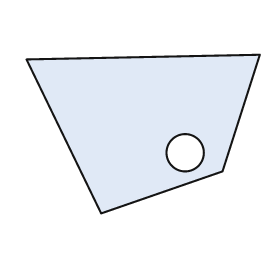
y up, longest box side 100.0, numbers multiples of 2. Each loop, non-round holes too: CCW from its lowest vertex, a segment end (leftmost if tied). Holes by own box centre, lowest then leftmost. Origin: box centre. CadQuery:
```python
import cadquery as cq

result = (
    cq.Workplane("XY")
    .moveTo(-18.0, -34.0)
    .lineTo(34.0, -16.0)
    .lineTo(50.0, 34.0)
    .lineTo(-50.0, 32.0)
    .close()
    .moveTo(18.0, -8.0)
    .circle(8.0)
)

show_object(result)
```